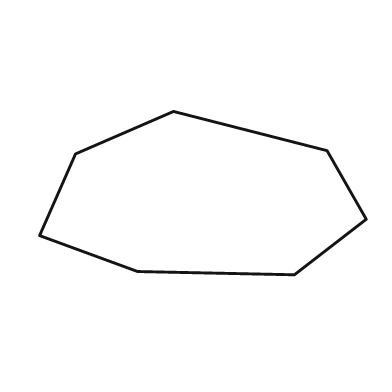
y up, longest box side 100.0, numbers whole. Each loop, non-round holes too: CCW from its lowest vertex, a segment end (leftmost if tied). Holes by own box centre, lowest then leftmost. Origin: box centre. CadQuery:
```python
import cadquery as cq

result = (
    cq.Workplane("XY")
    .moveTo(28.0, -25.0)
    .lineTo(50.0, -8.0)
    .lineTo(38.0, 13.0)
    .lineTo(-9.0, 25.0)
    .lineTo(-39.0, 12.0)
    .lineTo(-50.0, -13.0)
    .lineTo(-20.0, -24.0)
    .close()
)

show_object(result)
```